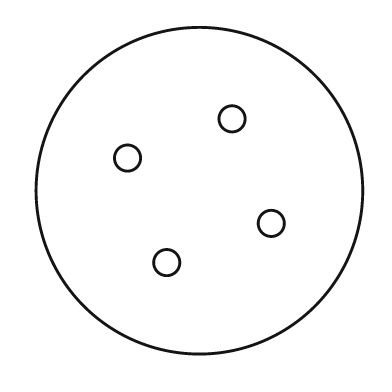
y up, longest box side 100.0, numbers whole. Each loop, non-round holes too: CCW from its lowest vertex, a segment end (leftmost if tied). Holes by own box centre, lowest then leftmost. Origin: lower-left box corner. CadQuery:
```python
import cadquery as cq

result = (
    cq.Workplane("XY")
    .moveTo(50.0, 50.0)
    .circle(50.0)
    .moveTo(40.0, 28.0)
    .circle(4.0)
    .moveTo(72.0, 40.0)
    .circle(4.0)
    .moveTo(28.0, 60.0)
    .circle(4.0)
    .moveTo(60.0, 72.0)
    .circle(4.0)
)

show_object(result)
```